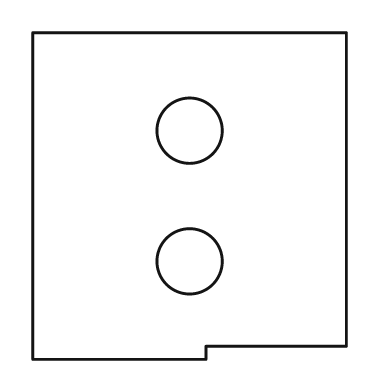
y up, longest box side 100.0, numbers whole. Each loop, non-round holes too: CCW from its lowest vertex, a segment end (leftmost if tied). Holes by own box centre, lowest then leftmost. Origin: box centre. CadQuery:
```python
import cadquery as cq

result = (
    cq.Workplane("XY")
    .moveTo(-48.0, -50.0)
    .lineTo(5.0, -50.0)
    .lineTo(5.0, -46.0)
    .lineTo(48.0, -46.0)
    .lineTo(48.0, 50.0)
    .lineTo(-48.0, 50.0)
    .close()
    .moveTo(0.0, -20.0)
    .circle(10.0)
    .moveTo(0.0, 20.0)
    .circle(10.0)
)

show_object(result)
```